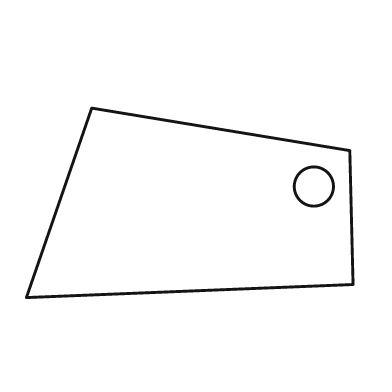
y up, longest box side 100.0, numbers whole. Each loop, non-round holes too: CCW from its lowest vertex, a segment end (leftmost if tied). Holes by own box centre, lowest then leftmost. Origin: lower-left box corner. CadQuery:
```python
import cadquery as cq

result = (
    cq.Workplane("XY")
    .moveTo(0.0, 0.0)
    .lineTo(100.0, 4.0)
    .lineTo(99.0, 45.0)
    .lineTo(20.0, 58.0)
    .close()
    .moveTo(88.0, 34.0)
    .circle(6.0)
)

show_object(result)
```